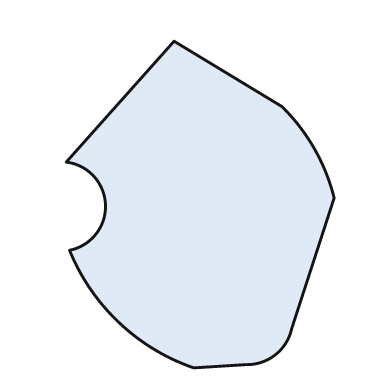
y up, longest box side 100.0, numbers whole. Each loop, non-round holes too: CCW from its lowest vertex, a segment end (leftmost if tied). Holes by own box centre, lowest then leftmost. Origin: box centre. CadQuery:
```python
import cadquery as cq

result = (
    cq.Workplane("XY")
    .moveTo(-2.0, -50.0)
    .lineTo(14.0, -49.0)
    .threePointArc((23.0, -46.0), (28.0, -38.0))
    .lineTo(41.0, 2.0)
    .threePointArc((35.0, 17.0), (25.0, 30.0))
    .lineTo(-8.0, 50.0)
    .lineTo(-41.0, 13.0)
    .threePointArc((-29.0, 0.0), (-40.0, -14.0))
    .threePointArc((-25.0, -36.0), (-2.0, -50.0))
    .close()
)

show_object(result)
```